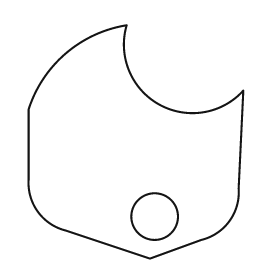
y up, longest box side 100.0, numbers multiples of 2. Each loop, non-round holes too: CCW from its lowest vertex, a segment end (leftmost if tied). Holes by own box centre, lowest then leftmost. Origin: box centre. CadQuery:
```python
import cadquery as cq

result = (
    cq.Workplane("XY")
    .moveTo(6.0, -50.0)
    .lineTo(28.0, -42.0)
    .threePointArc((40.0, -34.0), (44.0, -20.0))
    .lineTo(46.0, 22.0)
    .threePointArc((10.0, 16.0), (-4.0, 50.0))
    .threePointArc((-30.0, 38.0), (-46.0, 14.0))
    .lineTo(-46.0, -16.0)
    .threePointArc((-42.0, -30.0), (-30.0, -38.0))
    .close()
    .moveTo(8.0, -32.0)
    .circle(10.0)
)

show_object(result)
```